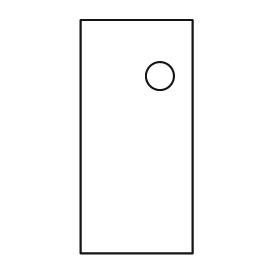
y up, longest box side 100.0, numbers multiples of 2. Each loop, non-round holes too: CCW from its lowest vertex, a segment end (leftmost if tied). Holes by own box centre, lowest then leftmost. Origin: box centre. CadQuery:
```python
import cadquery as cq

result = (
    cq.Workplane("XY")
    .moveTo(-24.0, -50.0)
    .lineTo(24.0, -50.0)
    .lineTo(24.0, 50.0)
    .lineTo(-24.0, 50.0)
    .close()
    .moveTo(10.0, 26.0)
    .circle(6.0)
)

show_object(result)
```